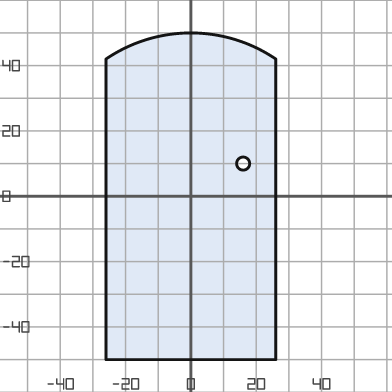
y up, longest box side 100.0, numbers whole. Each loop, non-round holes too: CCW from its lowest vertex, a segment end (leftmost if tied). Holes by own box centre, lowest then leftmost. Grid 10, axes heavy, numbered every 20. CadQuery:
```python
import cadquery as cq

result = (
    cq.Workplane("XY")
    .moveTo(-26.0, -50.0)
    .lineTo(26.0, -50.0)
    .lineTo(26.0, 42.0)
    .threePointArc((0.0, 50.0), (-26.0, 42.0))
    .close()
    .moveTo(16.0, 10.0)
    .circle(2.0)
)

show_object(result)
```